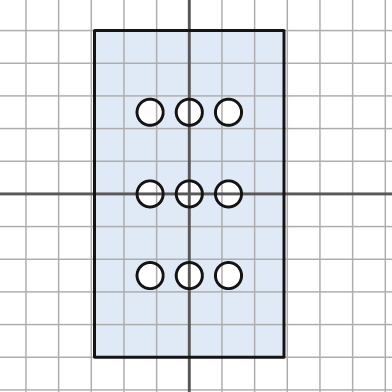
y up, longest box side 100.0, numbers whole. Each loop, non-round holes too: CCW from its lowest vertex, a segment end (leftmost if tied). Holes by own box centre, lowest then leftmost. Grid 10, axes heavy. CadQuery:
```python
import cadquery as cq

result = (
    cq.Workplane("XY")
    .moveTo(-29.0, -50.0)
    .lineTo(29.0, -50.0)
    .lineTo(29.0, 50.0)
    .lineTo(-29.0, 50.0)
    .close()
    .moveTo(-12.0, -25.0)
    .circle(4.0)
    .moveTo(0.0, -25.0)
    .circle(4.0)
    .moveTo(12.0, -25.0)
    .circle(4.0)
    .moveTo(-12.0, 0.0)
    .circle(4.0)
    .moveTo(0.0, 0.0)
    .circle(4.0)
    .moveTo(12.0, 0.0)
    .circle(4.0)
    .moveTo(-12.0, 25.0)
    .circle(4.0)
    .moveTo(0.0, 25.0)
    .circle(4.0)
    .moveTo(12.0, 25.0)
    .circle(4.0)
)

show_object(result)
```